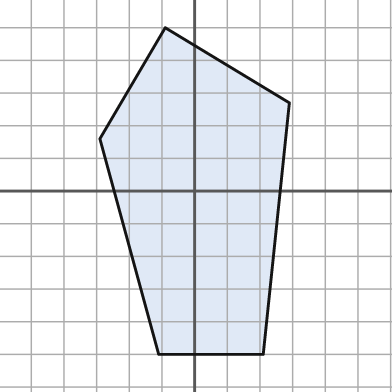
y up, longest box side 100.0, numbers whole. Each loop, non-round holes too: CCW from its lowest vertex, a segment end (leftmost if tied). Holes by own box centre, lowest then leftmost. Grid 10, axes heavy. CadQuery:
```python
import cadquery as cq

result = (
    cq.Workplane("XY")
    .moveTo(-11.0, -50.0)
    .lineTo(21.0, -50.0)
    .lineTo(29.0, 27.0)
    .lineTo(-9.0, 50.0)
    .lineTo(-29.0, 16.0)
    .close()
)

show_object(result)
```